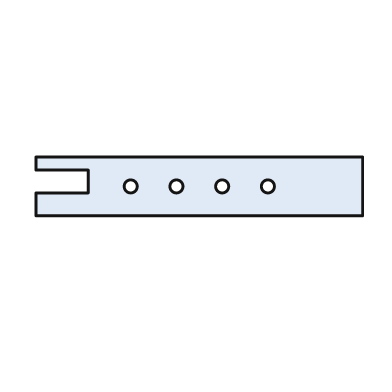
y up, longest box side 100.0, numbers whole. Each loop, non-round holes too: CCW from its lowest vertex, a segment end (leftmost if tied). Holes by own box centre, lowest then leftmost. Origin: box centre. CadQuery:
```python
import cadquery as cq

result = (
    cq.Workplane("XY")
    .moveTo(-50.0, -9.0)
    .lineTo(50.0, -9.0)
    .lineTo(50.0, 9.0)
    .lineTo(-50.0, 9.0)
    .lineTo(-50.0, 5.0)
    .lineTo(-34.0, 5.0)
    .lineTo(-34.0, -2.0)
    .lineTo(-50.0, -2.0)
    .close()
    .moveTo(-21.0, 0.0)
    .circle(2.0)
    .moveTo(-7.0, 0.0)
    .circle(2.0)
    .moveTo(7.0, 0.0)
    .circle(2.0)
    .moveTo(21.0, 0.0)
    .circle(2.0)
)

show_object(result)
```